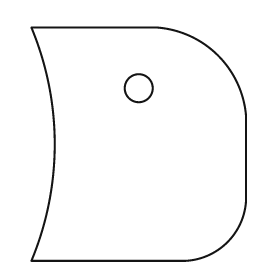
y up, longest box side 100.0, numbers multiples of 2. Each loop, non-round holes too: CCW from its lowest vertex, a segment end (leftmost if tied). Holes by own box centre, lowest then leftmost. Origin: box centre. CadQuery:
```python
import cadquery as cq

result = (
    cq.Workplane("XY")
    .moveTo(-46.0, -50.0)
    .lineTo(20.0, -50.0)
    .threePointArc((38.0, -42.0), (46.0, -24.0))
    .lineTo(46.0, 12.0)
    .threePointArc((34.0, 38.0), (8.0, 50.0))
    .lineTo(-46.0, 50.0)
    .threePointArc((-36.0, 0.0), (-46.0, -50.0))
    .close()
    .moveTo(0.0, 24.0)
    .circle(6.0)
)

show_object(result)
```